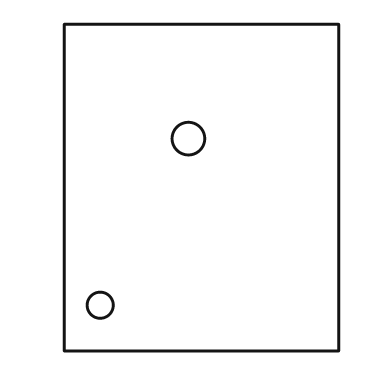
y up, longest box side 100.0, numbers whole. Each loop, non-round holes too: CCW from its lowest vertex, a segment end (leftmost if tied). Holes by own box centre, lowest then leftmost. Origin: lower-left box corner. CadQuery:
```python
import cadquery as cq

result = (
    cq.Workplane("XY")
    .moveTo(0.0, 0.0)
    .lineTo(84.0, 0.0)
    .lineTo(84.0, 100.0)
    .lineTo(0.0, 100.0)
    .close()
    .moveTo(11.0, 14.0)
    .circle(4.0)
    .moveTo(38.0, 65.0)
    .circle(5.0)
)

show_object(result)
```